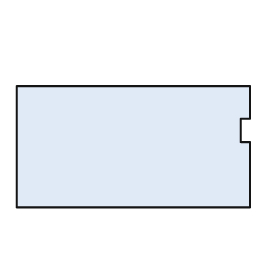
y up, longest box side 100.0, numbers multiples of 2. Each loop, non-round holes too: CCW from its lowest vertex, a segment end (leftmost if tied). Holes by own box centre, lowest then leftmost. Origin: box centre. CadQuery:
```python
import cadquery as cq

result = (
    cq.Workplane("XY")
    .moveTo(-50.0, -26.0)
    .lineTo(50.0, -26.0)
    .lineTo(50.0, 2.0)
    .lineTo(46.0, 2.0)
    .lineTo(46.0, 12.0)
    .lineTo(50.0, 12.0)
    .lineTo(50.0, 26.0)
    .lineTo(-50.0, 26.0)
    .close()
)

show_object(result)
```